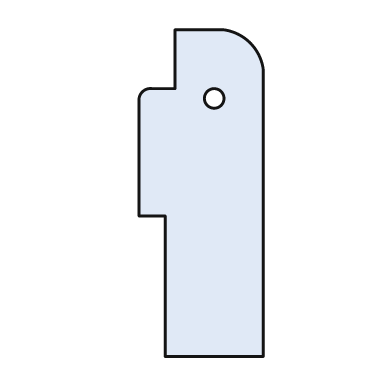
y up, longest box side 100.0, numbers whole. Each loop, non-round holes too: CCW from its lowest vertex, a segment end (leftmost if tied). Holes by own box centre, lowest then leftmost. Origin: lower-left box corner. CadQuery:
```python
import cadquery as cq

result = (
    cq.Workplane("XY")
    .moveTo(8.0, 0.0)
    .lineTo(38.0, 0.0)
    .lineTo(38.0, 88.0)
    .threePointArc((34.0, 96.0), (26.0, 100.0))
    .lineTo(11.0, 100.0)
    .lineTo(11.0, 82.0)
    .lineTo(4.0, 82.0)
    .threePointArc((1.0, 81.0), (0.0, 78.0))
    .lineTo(0.0, 43.0)
    .lineTo(8.0, 43.0)
    .close()
    .moveTo(23.0, 79.0)
    .circle(3.0)
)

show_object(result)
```